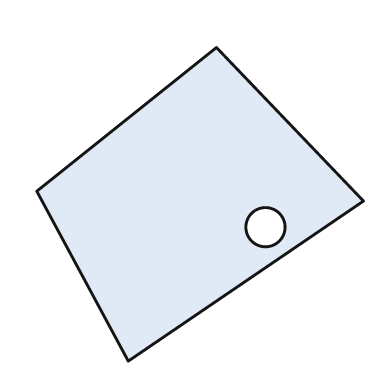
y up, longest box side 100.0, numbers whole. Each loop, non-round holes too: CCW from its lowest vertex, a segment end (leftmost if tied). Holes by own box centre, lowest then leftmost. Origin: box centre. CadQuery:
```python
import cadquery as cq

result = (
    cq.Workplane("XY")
    .moveTo(-22.0, -48.0)
    .lineTo(50.0, 1.0)
    .lineTo(5.0, 48.0)
    .lineTo(-50.0, 4.0)
    .close()
    .moveTo(20.0, -7.0)
    .circle(6.0)
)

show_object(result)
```